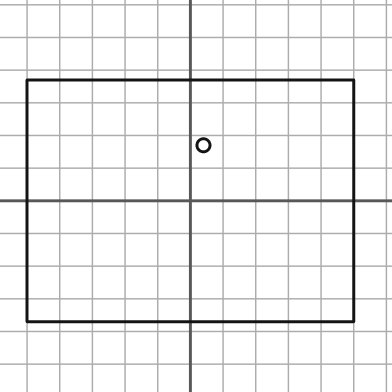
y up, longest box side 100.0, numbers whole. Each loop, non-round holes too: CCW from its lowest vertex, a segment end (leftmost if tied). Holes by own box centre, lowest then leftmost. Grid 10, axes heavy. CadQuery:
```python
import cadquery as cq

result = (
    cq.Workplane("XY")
    .moveTo(-50.0, -37.0)
    .lineTo(50.0, -37.0)
    .lineTo(50.0, 37.0)
    .lineTo(-50.0, 37.0)
    .close()
    .moveTo(4.0, 17.0)
    .circle(2.0)
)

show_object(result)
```